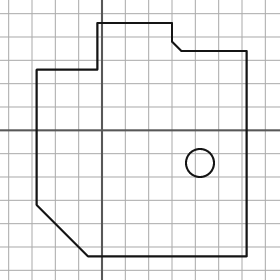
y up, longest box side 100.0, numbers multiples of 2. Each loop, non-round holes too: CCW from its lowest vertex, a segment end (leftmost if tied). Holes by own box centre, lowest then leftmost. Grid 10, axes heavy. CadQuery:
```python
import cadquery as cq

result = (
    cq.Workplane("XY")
    .moveTo(-6.0, -54.0)
    .lineTo(62.0, -54.0)
    .lineTo(62.0, 34.0)
    .lineTo(34.0, 34.0)
    .lineTo(30.0, 38.0)
    .lineTo(30.0, 46.0)
    .lineTo(-2.0, 46.0)
    .lineTo(-2.0, 26.0)
    .lineTo(-28.0, 26.0)
    .lineTo(-28.0, -32.0)
    .close()
    .moveTo(42.0, -14.0)
    .circle(6.0)
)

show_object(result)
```